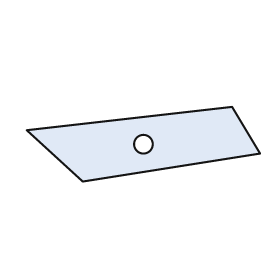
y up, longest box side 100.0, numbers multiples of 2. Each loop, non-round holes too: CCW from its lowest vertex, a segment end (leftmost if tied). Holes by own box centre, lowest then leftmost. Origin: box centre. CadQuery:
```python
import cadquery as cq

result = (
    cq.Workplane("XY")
    .moveTo(-26.0, -16.0)
    .lineTo(50.0, -4.0)
    .lineTo(38.0, 16.0)
    .lineTo(-50.0, 6.0)
    .close()
    .moveTo(0.0, 0.0)
    .circle(4.0)
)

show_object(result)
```